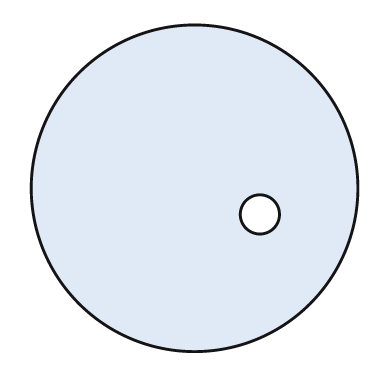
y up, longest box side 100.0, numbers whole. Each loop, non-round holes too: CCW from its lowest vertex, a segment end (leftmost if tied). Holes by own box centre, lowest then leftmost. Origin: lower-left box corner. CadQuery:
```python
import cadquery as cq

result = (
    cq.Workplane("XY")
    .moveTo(50.0, 50.0)
    .circle(50.0)
    .moveTo(70.0, 42.0)
    .circle(6.0)
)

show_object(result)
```